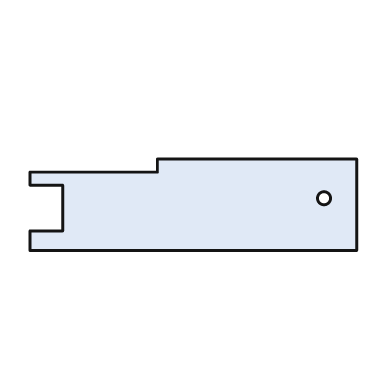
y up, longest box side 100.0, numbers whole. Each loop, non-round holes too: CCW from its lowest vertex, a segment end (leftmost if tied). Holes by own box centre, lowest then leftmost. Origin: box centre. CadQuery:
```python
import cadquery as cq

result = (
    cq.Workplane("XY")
    .moveTo(-50.0, -14.0)
    .lineTo(50.0, -14.0)
    .lineTo(50.0, 14.0)
    .lineTo(-11.0, 14.0)
    .lineTo(-11.0, 10.0)
    .lineTo(-50.0, 10.0)
    .lineTo(-50.0, 6.0)
    .lineTo(-40.0, 6.0)
    .lineTo(-40.0, -8.0)
    .lineTo(-50.0, -8.0)
    .close()
    .moveTo(40.0, 2.0)
    .circle(2.0)
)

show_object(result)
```